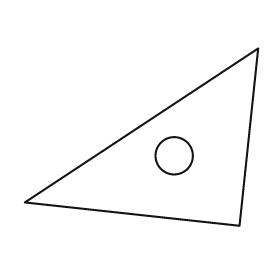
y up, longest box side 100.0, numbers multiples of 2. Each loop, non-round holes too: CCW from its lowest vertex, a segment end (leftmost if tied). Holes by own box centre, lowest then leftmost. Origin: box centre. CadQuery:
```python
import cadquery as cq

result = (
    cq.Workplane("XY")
    .moveTo(42.0, -38.0)
    .lineTo(50.0, 38.0)
    .lineTo(-50.0, -28.0)
    .close()
    .moveTo(14.0, -8.0)
    .circle(8.0)
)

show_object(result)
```